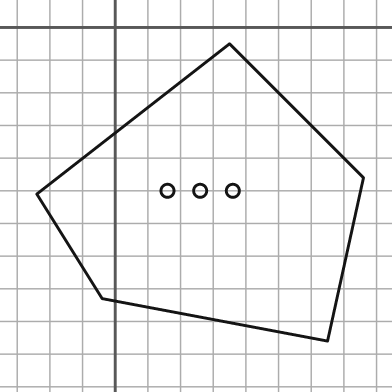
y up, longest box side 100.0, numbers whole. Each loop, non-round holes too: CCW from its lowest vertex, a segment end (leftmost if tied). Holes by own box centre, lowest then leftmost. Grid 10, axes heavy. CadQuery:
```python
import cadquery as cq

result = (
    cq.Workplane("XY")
    .moveTo(65.0, -96.0)
    .lineTo(76.0, -46.0)
    .lineTo(35.0, -5.0)
    .lineTo(-24.0, -51.0)
    .lineTo(-4.0, -83.0)
    .close()
    .moveTo(16.0, -50.0)
    .circle(2.0)
    .moveTo(26.0, -50.0)
    .circle(2.0)
    .moveTo(36.0, -50.0)
    .circle(2.0)
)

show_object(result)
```